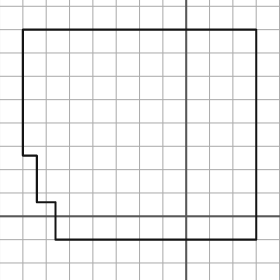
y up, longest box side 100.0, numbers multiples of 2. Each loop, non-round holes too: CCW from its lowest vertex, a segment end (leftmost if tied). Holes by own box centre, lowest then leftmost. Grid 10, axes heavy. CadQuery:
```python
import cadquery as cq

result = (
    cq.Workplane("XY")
    .moveTo(-56.0, -10.0)
    .lineTo(30.0, -10.0)
    .lineTo(30.0, 80.0)
    .lineTo(-70.0, 80.0)
    .lineTo(-70.0, 26.0)
    .lineTo(-64.0, 26.0)
    .lineTo(-64.0, 6.0)
    .lineTo(-56.0, 6.0)
    .close()
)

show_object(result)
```